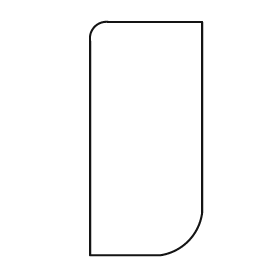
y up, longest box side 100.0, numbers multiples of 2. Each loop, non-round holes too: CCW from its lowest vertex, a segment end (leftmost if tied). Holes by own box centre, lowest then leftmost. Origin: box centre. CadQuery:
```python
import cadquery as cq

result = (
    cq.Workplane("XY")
    .moveTo(-24.0, -50.0)
    .lineTo(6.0, -50.0)
    .threePointArc((18.0, -44.0), (24.0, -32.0))
    .lineTo(24.0, 50.0)
    .lineTo(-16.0, 50.0)
    .threePointArc((-22.0, 48.0), (-24.0, 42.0))
    .close()
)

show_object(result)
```